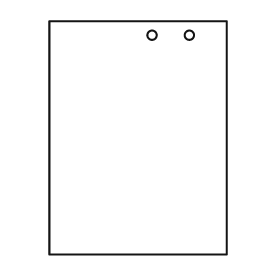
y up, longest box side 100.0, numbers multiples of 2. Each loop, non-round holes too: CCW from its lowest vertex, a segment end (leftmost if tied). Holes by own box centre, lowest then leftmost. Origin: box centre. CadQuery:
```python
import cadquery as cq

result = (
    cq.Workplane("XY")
    .moveTo(-38.0, -50.0)
    .lineTo(38.0, -50.0)
    .lineTo(38.0, 50.0)
    .lineTo(-38.0, 50.0)
    .close()
    .moveTo(6.0, 44.0)
    .circle(2.0)
    .moveTo(22.0, 44.0)
    .circle(2.0)
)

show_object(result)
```